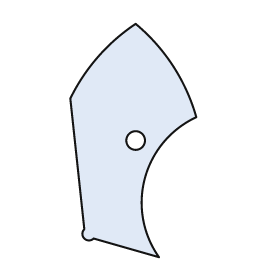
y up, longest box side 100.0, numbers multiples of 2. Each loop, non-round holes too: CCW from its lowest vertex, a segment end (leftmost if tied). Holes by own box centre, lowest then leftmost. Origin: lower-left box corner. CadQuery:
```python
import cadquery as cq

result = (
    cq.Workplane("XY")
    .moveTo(38.0, 0.0)
    .threePointArc((32.0, 34.0), (54.0, 60.0))
    .threePointArc((44.0, 82.0), (28.0, 100.0))
    .threePointArc((12.0, 86.0), (0.0, 68.0))
    .lineTo(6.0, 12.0)
    .threePointArc((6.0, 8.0), (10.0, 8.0))
    .close()
    .moveTo(28.0, 50.0)
    .circle(4.0)
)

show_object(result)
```